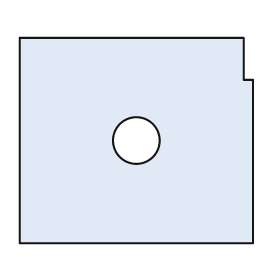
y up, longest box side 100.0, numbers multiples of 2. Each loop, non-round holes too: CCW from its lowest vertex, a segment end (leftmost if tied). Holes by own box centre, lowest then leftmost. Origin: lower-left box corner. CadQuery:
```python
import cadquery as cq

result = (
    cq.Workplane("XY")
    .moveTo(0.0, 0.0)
    .lineTo(100.0, 0.0)
    .lineTo(100.0, 70.0)
    .lineTo(96.0, 70.0)
    .lineTo(96.0, 88.0)
    .lineTo(0.0, 88.0)
    .close()
    .moveTo(50.0, 44.0)
    .circle(10.0)
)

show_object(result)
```